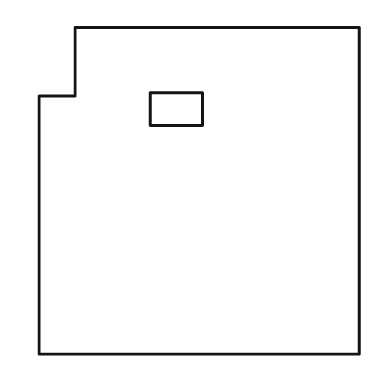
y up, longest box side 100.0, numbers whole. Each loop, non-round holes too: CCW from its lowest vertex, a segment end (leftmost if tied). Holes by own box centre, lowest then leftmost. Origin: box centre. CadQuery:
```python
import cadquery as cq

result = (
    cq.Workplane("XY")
    .moveTo(-49.0, -50.0)
    .lineTo(49.0, -50.0)
    .lineTo(49.0, 50.0)
    .lineTo(-38.0, 50.0)
    .lineTo(-38.0, 29.0)
    .lineTo(-49.0, 29.0)
    .close()
    .moveTo(-15.0, 20.0)
    .lineTo(1.0, 20.0)
    .lineTo(1.0, 30.0)
    .lineTo(-15.0, 30.0)
    .close()
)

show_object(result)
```